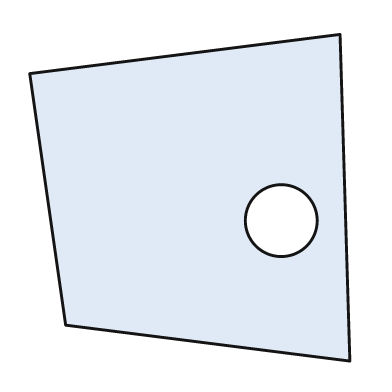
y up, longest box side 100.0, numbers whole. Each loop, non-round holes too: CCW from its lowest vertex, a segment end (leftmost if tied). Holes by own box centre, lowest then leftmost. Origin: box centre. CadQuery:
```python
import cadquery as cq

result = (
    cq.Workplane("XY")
    .moveTo(49.0, -50.0)
    .lineTo(46.0, 50.0)
    .lineTo(-49.0, 38.0)
    .lineTo(-38.0, -39.0)
    .close()
    .moveTo(28.0, -7.0)
    .circle(11.0)
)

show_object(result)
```